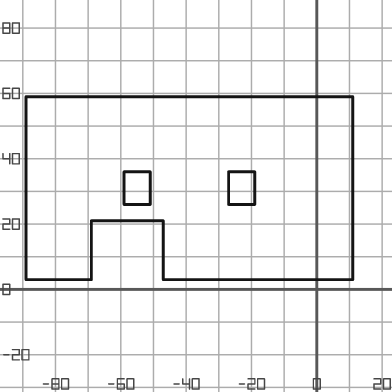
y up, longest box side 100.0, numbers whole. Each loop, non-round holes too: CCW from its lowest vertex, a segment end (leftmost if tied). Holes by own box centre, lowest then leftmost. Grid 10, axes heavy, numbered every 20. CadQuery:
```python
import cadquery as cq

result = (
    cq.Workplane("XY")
    .moveTo(-89.0, 3.0)
    .lineTo(-69.0, 3.0)
    .lineTo(-69.0, 21.0)
    .lineTo(-47.0, 21.0)
    .lineTo(-47.0, 3.0)
    .lineTo(11.0, 3.0)
    .lineTo(11.0, 59.0)
    .lineTo(-89.0, 59.0)
    .close()
    .moveTo(-59.0, 26.0)
    .lineTo(-51.0, 26.0)
    .lineTo(-51.0, 36.0)
    .lineTo(-59.0, 36.0)
    .close()
    .moveTo(-27.0, 26.0)
    .lineTo(-19.0, 26.0)
    .lineTo(-19.0, 36.0)
    .lineTo(-27.0, 36.0)
    .close()
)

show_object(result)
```